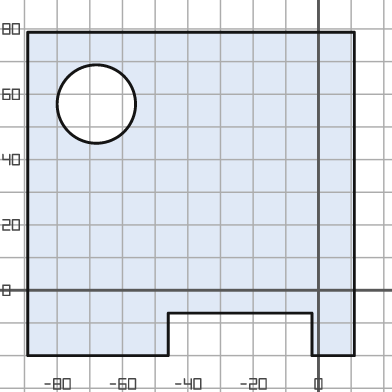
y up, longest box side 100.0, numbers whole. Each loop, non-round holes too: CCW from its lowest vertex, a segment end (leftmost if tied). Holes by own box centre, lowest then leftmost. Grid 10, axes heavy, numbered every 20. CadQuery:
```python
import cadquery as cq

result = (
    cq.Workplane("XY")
    .moveTo(-89.0, -20.0)
    .lineTo(-46.0, -20.0)
    .lineTo(-46.0, -7.0)
    .lineTo(-2.0, -7.0)
    .lineTo(-2.0, -20.0)
    .lineTo(11.0, -20.0)
    .lineTo(11.0, 79.0)
    .lineTo(-89.0, 79.0)
    .close()
    .moveTo(-68.0, 57.0)
    .circle(12.0)
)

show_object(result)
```